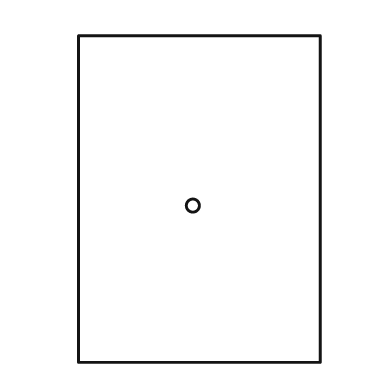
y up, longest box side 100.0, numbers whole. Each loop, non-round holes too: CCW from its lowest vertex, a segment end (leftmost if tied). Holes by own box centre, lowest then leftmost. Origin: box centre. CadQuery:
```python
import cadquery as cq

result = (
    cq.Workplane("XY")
    .moveTo(-37.0, -50.0)
    .lineTo(37.0, -50.0)
    .lineTo(37.0, 50.0)
    .lineTo(-37.0, 50.0)
    .close()
    .moveTo(-2.0, -2.0)
    .circle(2.0)
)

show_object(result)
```